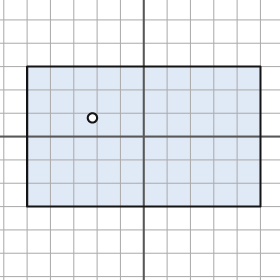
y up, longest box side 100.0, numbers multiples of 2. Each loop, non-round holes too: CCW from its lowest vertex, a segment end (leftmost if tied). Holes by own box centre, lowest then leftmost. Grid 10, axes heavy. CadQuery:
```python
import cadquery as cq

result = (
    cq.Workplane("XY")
    .moveTo(-50.0, -30.0)
    .lineTo(50.0, -30.0)
    .lineTo(50.0, 30.0)
    .lineTo(-50.0, 30.0)
    .close()
    .moveTo(-22.0, 8.0)
    .circle(2.0)
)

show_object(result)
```